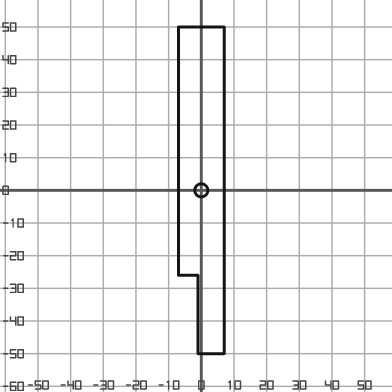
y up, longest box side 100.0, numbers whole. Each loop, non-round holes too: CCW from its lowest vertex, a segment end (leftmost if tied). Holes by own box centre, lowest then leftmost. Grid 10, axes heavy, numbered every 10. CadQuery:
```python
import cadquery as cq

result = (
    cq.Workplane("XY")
    .moveTo(-1.0, -50.0)
    .lineTo(7.0, -50.0)
    .lineTo(7.0, 50.0)
    .lineTo(-7.0, 50.0)
    .lineTo(-7.0, -26.0)
    .lineTo(-1.0, -26.0)
    .close()
    .moveTo(0.0, 0.0)
    .circle(2.0)
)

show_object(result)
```